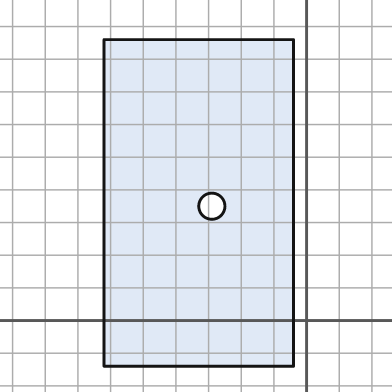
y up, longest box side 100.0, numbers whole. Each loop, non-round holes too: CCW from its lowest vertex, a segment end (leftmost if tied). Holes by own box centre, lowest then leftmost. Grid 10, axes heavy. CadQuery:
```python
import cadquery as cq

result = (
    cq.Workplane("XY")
    .moveTo(-62.0, -14.0)
    .lineTo(-4.0, -14.0)
    .lineTo(-4.0, 86.0)
    .lineTo(-62.0, 86.0)
    .close()
    .moveTo(-29.0, 35.0)
    .circle(4.0)
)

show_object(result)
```